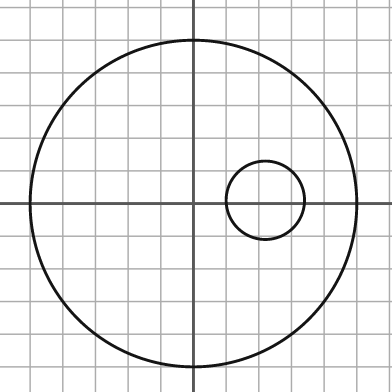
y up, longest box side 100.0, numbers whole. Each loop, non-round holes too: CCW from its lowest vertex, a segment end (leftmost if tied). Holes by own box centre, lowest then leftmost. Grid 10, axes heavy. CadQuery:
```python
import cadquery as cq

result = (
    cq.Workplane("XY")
    .moveTo(0.0, 0.0)
    .circle(50.0)
    .moveTo(22.0, 1.0)
    .circle(12.0)
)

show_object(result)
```